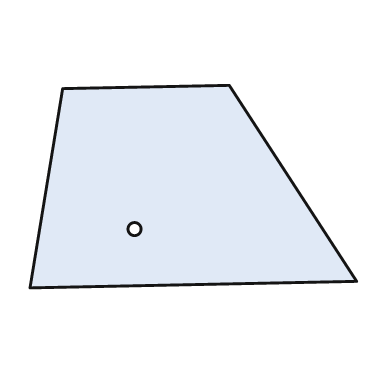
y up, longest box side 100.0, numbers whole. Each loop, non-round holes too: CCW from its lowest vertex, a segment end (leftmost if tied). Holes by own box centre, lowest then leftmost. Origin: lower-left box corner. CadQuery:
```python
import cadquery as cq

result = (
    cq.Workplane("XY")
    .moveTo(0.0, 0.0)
    .lineTo(100.0, 2.0)
    .lineTo(61.0, 62.0)
    .lineTo(10.0, 61.0)
    .close()
    .moveTo(32.0, 18.0)
    .circle(2.0)
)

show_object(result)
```